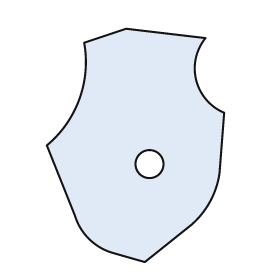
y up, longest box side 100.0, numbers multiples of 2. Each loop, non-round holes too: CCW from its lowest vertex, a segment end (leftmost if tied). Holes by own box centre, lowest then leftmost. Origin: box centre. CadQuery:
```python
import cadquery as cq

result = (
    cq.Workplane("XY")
    .moveTo(4.0, -50.0)
    .lineTo(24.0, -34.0)
    .threePointArc((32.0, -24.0), (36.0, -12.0))
    .lineTo(38.0, 14.0)
    .threePointArc((26.0, 28.0), (30.0, 46.0))
    .lineTo(-4.0, 50.0)
    .lineTo(-22.0, 44.0)
    .threePointArc((-24.0, 20.0), (-38.0, 0.0))
    .lineTo(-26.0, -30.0)
    .threePointArc((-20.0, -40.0), (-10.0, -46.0))
    .close()
    .moveTo(6.0, -8.0)
    .circle(6.0)
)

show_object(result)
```